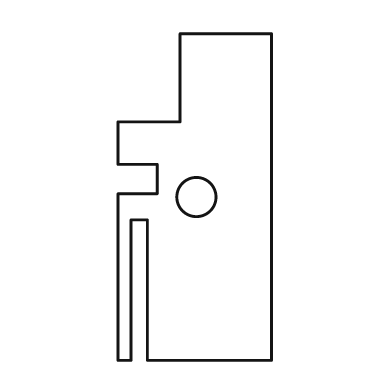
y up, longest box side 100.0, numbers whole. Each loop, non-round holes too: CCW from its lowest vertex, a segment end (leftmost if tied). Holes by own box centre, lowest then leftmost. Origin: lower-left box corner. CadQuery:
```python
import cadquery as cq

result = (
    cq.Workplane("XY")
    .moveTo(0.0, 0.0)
    .lineTo(4.0, 0.0)
    .lineTo(4.0, 43.0)
    .lineTo(9.0, 43.0)
    .lineTo(9.0, 0.0)
    .lineTo(47.0, 0.0)
    .lineTo(47.0, 100.0)
    .lineTo(19.0, 100.0)
    .lineTo(19.0, 73.0)
    .lineTo(0.0, 73.0)
    .lineTo(0.0, 60.0)
    .lineTo(12.0, 60.0)
    .lineTo(12.0, 51.0)
    .lineTo(0.0, 51.0)
    .close()
    .moveTo(24.0, 50.0)
    .circle(6.0)
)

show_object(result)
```